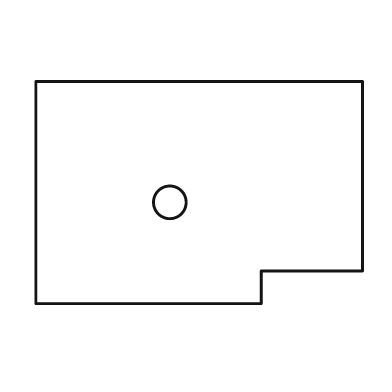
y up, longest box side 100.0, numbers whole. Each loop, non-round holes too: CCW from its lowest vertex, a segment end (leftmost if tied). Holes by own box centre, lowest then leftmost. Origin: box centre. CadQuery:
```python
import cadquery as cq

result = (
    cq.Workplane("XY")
    .moveTo(-50.0, -34.0)
    .lineTo(19.0, -34.0)
    .lineTo(19.0, -24.0)
    .lineTo(50.0, -24.0)
    .lineTo(50.0, 34.0)
    .lineTo(-50.0, 34.0)
    .close()
    .moveTo(-9.0, -3.0)
    .circle(5.0)
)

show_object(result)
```